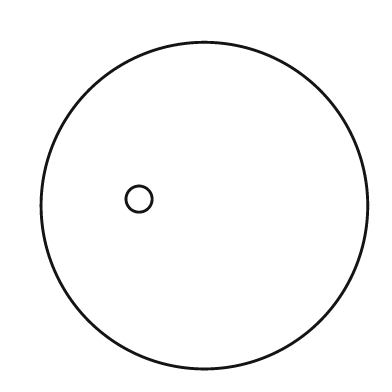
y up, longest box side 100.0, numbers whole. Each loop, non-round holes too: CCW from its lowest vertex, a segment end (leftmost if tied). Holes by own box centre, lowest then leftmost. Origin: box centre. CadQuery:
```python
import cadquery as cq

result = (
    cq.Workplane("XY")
    .moveTo(0.0, 0.0)
    .circle(50.0)
    .moveTo(-20.0, 2.0)
    .circle(4.0)
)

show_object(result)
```